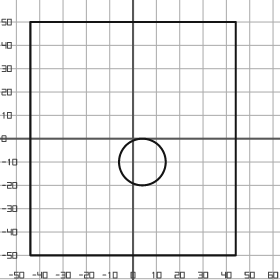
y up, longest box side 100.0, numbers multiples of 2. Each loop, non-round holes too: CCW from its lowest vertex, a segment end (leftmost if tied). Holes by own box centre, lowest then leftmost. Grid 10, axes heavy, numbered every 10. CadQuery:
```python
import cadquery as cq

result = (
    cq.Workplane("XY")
    .moveTo(-44.0, -50.0)
    .lineTo(44.0, -50.0)
    .lineTo(44.0, 50.0)
    .lineTo(-44.0, 50.0)
    .close()
    .moveTo(4.0, -10.0)
    .circle(10.0)
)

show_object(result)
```